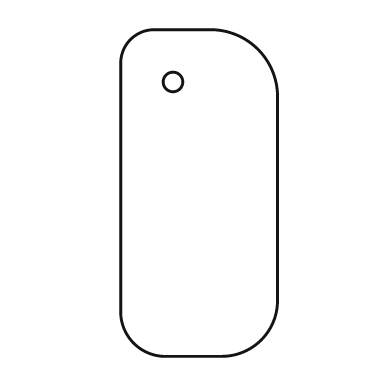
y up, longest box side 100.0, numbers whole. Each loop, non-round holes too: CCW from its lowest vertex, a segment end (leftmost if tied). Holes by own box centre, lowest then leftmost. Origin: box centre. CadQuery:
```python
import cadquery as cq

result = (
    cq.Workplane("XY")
    .moveTo(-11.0, -50.0)
    .lineTo(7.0, -50.0)
    .threePointArc((19.0, -45.0), (24.0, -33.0))
    .lineTo(24.0, 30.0)
    .threePointArc((18.0, 44.0), (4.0, 50.0))
    .lineTo(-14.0, 50.0)
    .threePointArc((-21.0, 47.0), (-24.0, 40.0))
    .lineTo(-24.0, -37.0)
    .threePointArc((-20.0, -46.0), (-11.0, -50.0))
    .close()
    .moveTo(-8.0, 34.0)
    .circle(3.0)
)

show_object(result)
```